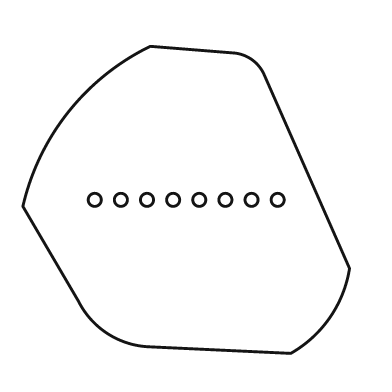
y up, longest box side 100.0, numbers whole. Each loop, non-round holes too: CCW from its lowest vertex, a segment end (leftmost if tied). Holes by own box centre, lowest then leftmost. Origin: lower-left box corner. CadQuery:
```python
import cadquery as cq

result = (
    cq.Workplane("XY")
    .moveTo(82.0, 0.0)
    .threePointArc((94.0, 11.0), (100.0, 26.0))
    .lineTo(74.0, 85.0)
    .threePointArc((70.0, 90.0), (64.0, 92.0))
    .lineTo(39.0, 94.0)
    .threePointArc((14.0, 74.0), (0.0, 45.0))
    .lineTo(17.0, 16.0)
    .threePointArc((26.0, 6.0), (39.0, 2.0))
    .close()
    .moveTo(22.0, 47.0)
    .circle(2.0)
    .moveTo(30.0, 47.0)
    .circle(2.0)
    .moveTo(38.0, 47.0)
    .circle(2.0)
    .moveTo(46.0, 47.0)
    .circle(2.0)
    .moveTo(54.0, 47.0)
    .circle(2.0)
    .moveTo(62.0, 47.0)
    .circle(2.0)
    .moveTo(70.0, 47.0)
    .circle(2.0)
    .moveTo(78.0, 47.0)
    .circle(2.0)
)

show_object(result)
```